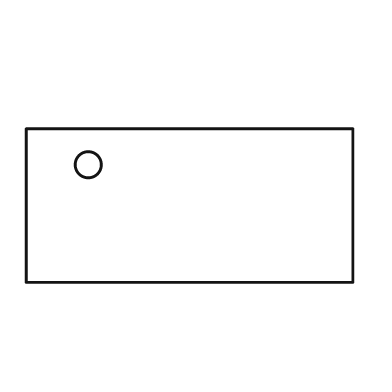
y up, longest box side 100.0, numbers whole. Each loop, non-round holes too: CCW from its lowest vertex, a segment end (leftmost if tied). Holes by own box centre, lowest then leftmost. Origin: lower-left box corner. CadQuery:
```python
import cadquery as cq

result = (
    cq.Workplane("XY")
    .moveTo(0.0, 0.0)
    .lineTo(100.0, 0.0)
    .lineTo(100.0, 47.0)
    .lineTo(0.0, 47.0)
    .close()
    .moveTo(19.0, 36.0)
    .circle(4.0)
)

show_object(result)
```